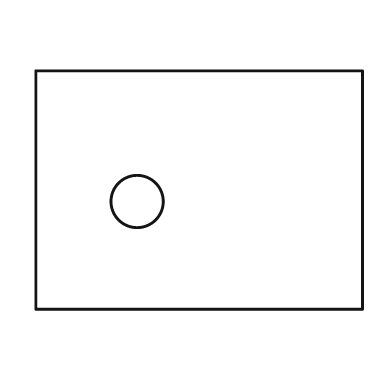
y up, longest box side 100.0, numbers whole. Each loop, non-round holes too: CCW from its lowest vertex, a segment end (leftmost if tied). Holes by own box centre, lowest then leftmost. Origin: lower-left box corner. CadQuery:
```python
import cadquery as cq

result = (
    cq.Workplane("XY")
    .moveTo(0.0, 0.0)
    .lineTo(100.0, 0.0)
    .lineTo(100.0, 73.0)
    .lineTo(0.0, 73.0)
    .close()
    .moveTo(31.0, 33.0)
    .circle(8.0)
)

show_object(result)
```